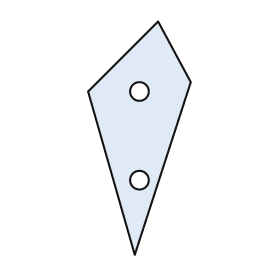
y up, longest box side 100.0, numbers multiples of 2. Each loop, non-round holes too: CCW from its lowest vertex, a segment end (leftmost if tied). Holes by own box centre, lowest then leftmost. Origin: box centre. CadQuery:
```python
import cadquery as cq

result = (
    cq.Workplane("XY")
    .moveTo(-2.0, -50.0)
    .lineTo(22.0, 24.0)
    .lineTo(8.0, 50.0)
    .lineTo(-22.0, 20.0)
    .close()
    .moveTo(0.0, -18.0)
    .circle(4.0)
    .moveTo(0.0, 20.0)
    .circle(4.0)
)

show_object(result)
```